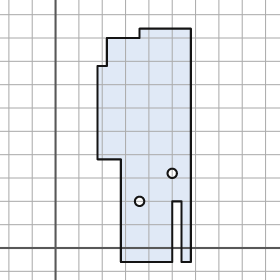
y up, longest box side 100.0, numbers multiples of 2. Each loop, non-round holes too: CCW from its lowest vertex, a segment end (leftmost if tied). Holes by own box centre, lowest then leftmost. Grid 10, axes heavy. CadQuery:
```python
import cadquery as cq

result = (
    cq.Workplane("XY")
    .moveTo(28.0, -6.0)
    .lineTo(50.0, -6.0)
    .lineTo(50.0, 20.0)
    .lineTo(54.0, 20.0)
    .lineTo(54.0, -6.0)
    .lineTo(58.0, -6.0)
    .lineTo(58.0, 94.0)
    .lineTo(36.0, 94.0)
    .lineTo(36.0, 90.0)
    .lineTo(22.0, 90.0)
    .lineTo(22.0, 78.0)
    .lineTo(18.0, 78.0)
    .lineTo(18.0, 38.0)
    .lineTo(28.0, 38.0)
    .close()
    .moveTo(36.0, 20.0)
    .circle(2.0)
    .moveTo(50.0, 32.0)
    .circle(2.0)
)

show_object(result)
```